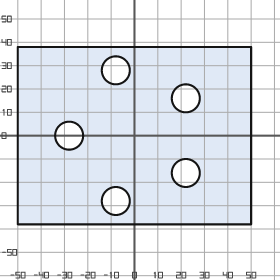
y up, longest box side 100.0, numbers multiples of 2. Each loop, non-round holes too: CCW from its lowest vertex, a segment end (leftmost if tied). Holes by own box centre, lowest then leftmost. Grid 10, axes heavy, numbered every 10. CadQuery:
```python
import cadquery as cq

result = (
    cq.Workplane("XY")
    .moveTo(-50.0, -38.0)
    .lineTo(50.0, -38.0)
    .lineTo(50.0, 38.0)
    .lineTo(-50.0, 38.0)
    .close()
    .moveTo(-8.0, -28.0)
    .circle(6.0)
    .moveTo(22.0, -16.0)
    .circle(6.0)
    .moveTo(-28.0, 0.0)
    .circle(6.0)
    .moveTo(22.0, 16.0)
    .circle(6.0)
    .moveTo(-8.0, 28.0)
    .circle(6.0)
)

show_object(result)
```